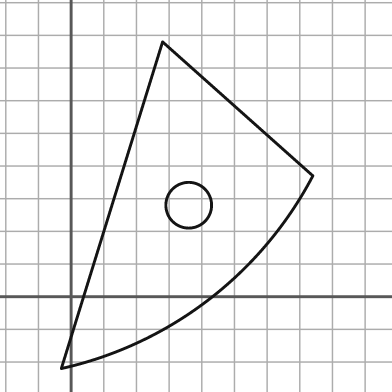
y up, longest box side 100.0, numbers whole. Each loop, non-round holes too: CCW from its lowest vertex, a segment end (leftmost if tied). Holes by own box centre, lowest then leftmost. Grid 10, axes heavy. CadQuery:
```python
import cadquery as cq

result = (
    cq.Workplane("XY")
    .moveTo(-3.0, -22.0)
    .threePointArc((42.0, -1.0), (74.0, 37.0))
    .lineTo(28.0, 78.0)
    .close()
    .moveTo(36.0, 28.0)
    .circle(7.0)
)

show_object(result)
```